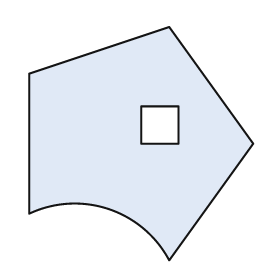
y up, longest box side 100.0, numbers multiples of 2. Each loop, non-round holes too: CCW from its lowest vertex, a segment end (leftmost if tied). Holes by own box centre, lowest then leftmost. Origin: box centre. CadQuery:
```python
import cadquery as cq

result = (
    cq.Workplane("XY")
    .moveTo(12.0, -50.0)
    .lineTo(48.0, 0.0)
    .lineTo(12.0, 50.0)
    .lineTo(-48.0, 30.0)
    .lineTo(-48.0, -30.0)
    .threePointArc((-14.0, -28.0), (12.0, -50.0))
    .close()
    .moveTo(0.0, 0.0)
    .lineTo(16.0, 0.0)
    .lineTo(16.0, 16.0)
    .lineTo(0.0, 16.0)
    .close()
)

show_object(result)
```